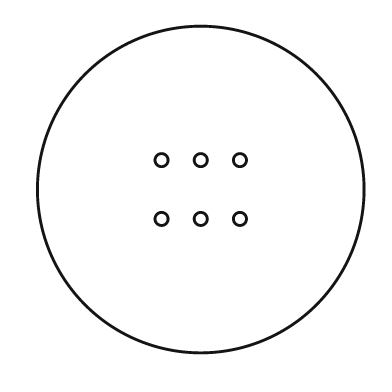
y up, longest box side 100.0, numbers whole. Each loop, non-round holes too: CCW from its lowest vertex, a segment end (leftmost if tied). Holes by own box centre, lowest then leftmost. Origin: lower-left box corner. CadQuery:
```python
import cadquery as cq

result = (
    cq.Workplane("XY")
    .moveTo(50.0, 50.0)
    .circle(50.0)
    .moveTo(38.0, 41.0)
    .circle(2.0)
    .moveTo(50.0, 41.0)
    .circle(2.0)
    .moveTo(62.0, 41.0)
    .circle(2.0)
    .moveTo(38.0, 59.0)
    .circle(2.0)
    .moveTo(50.0, 59.0)
    .circle(2.0)
    .moveTo(62.0, 59.0)
    .circle(2.0)
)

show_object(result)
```